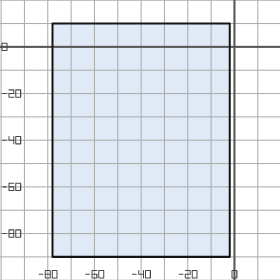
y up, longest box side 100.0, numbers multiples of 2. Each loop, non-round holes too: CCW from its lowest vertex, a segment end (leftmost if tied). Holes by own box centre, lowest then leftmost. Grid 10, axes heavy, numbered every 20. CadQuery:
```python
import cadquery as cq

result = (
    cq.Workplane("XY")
    .moveTo(-78.0, -90.0)
    .lineTo(-2.0, -90.0)
    .lineTo(-2.0, 10.0)
    .lineTo(-78.0, 10.0)
    .close()
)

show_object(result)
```